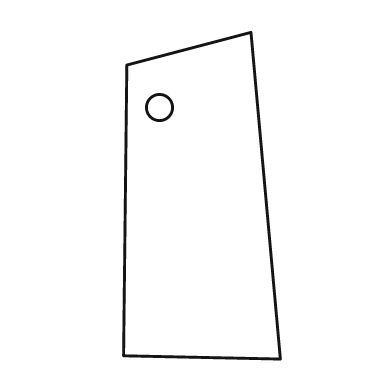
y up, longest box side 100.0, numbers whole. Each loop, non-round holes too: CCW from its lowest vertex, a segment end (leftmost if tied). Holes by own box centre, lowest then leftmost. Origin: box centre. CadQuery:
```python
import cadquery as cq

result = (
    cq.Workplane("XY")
    .moveTo(24.0, -50.0)
    .lineTo(15.0, 50.0)
    .lineTo(-23.0, 40.0)
    .lineTo(-24.0, -49.0)
    .close()
    .moveTo(-13.0, 27.0)
    .circle(4.0)
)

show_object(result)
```